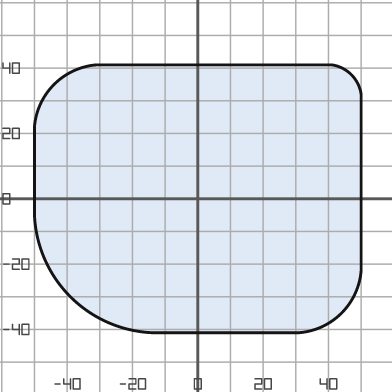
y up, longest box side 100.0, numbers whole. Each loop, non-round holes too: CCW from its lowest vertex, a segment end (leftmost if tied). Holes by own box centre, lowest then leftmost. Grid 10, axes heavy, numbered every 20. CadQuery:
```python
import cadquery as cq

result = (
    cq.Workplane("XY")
    .moveTo(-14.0, -41.0)
    .lineTo(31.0, -41.0)
    .threePointArc((44.0, -35.0), (50.0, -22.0))
    .lineTo(50.0, 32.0)
    .threePointArc((47.0, 38.0), (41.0, 41.0))
    .lineTo(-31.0, 41.0)
    .threePointArc((-44.0, 35.0), (-50.0, 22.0))
    .lineTo(-50.0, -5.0)
    .threePointArc((-39.0, -30.0), (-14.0, -41.0))
    .close()
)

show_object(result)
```